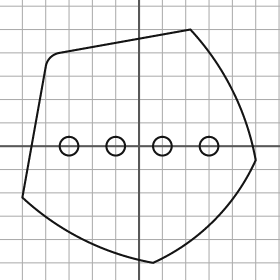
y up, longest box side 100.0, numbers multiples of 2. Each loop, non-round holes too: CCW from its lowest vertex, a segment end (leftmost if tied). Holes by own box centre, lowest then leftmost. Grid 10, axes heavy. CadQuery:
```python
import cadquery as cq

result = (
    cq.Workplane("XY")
    .moveTo(6.0, -50.0)
    .threePointArc((32.0, -32.0), (50.0, -6.0))
    .threePointArc((40.0, 24.0), (22.0, 50.0))
    .lineTo(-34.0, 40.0)
    .threePointArc((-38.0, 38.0), (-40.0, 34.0))
    .lineTo(-50.0, -22.0)
    .threePointArc((-24.0, -40.0), (6.0, -50.0))
    .close()
    .moveTo(-30.0, 0.0)
    .circle(4.0)
    .moveTo(-10.0, 0.0)
    .circle(4.0)
    .moveTo(10.0, 0.0)
    .circle(4.0)
    .moveTo(30.0, 0.0)
    .circle(4.0)
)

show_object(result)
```